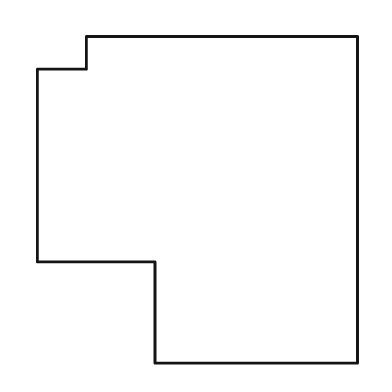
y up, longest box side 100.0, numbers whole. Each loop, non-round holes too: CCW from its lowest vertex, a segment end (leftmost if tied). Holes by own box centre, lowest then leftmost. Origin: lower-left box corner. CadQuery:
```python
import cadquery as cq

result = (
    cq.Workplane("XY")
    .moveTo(36.0, 0.0)
    .lineTo(98.0, 0.0)
    .lineTo(98.0, 100.0)
    .lineTo(15.0, 100.0)
    .lineTo(15.0, 90.0)
    .lineTo(0.0, 90.0)
    .lineTo(0.0, 31.0)
    .lineTo(36.0, 31.0)
    .close()
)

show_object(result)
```